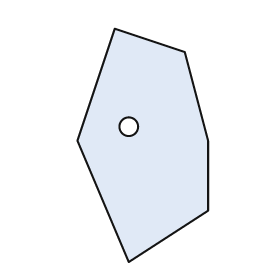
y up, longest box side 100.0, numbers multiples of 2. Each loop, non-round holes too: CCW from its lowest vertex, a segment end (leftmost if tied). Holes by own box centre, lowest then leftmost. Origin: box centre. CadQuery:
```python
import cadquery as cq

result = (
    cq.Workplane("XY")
    .moveTo(-6.0, -50.0)
    .lineTo(28.0, -28.0)
    .lineTo(28.0, 2.0)
    .lineTo(18.0, 40.0)
    .lineTo(-12.0, 50.0)
    .lineTo(-28.0, 2.0)
    .close()
    .moveTo(-6.0, 8.0)
    .circle(4.0)
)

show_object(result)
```